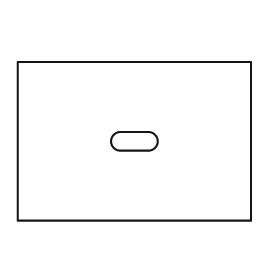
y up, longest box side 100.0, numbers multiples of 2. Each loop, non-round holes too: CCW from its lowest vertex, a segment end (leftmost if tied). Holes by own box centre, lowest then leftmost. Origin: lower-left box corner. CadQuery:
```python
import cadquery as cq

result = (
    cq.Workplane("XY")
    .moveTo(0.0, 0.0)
    .lineTo(100.0, 0.0)
    .lineTo(100.0, 68.0)
    .lineTo(0.0, 68.0)
    .close()
    .moveTo(44.0, 30.0)
    .lineTo(56.0, 30.0)
    .threePointArc((60.0, 34.0), (56.0, 38.0))
    .lineTo(44.0, 38.0)
    .threePointArc((40.0, 34.0), (44.0, 30.0))
    .close()
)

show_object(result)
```